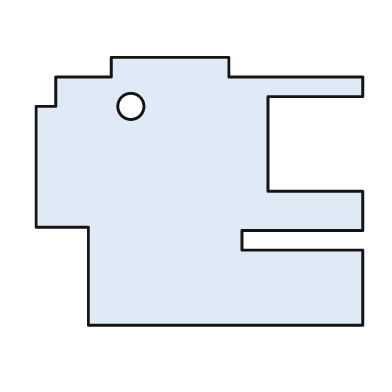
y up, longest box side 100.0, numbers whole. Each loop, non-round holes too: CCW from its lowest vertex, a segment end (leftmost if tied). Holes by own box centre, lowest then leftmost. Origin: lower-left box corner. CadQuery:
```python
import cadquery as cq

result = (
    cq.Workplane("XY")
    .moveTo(16.0, 0.0)
    .lineTo(100.0, 0.0)
    .lineTo(100.0, 23.0)
    .lineTo(63.0, 23.0)
    .lineTo(63.0, 29.0)
    .lineTo(100.0, 29.0)
    .lineTo(100.0, 41.0)
    .lineTo(71.0, 41.0)
    .lineTo(71.0, 70.0)
    .lineTo(100.0, 70.0)
    .lineTo(100.0, 76.0)
    .lineTo(59.0, 76.0)
    .lineTo(59.0, 82.0)
    .lineTo(23.0, 82.0)
    .lineTo(23.0, 76.0)
    .lineTo(6.0, 76.0)
    .lineTo(6.0, 67.0)
    .lineTo(0.0, 67.0)
    .lineTo(0.0, 30.0)
    .lineTo(16.0, 30.0)
    .close()
    .moveTo(29.0, 67.0)
    .circle(4.0)
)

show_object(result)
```